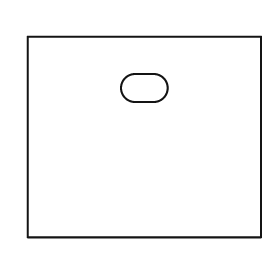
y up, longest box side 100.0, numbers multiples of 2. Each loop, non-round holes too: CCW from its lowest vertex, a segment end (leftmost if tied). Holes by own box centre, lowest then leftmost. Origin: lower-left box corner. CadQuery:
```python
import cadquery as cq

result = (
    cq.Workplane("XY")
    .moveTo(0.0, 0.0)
    .lineTo(100.0, 0.0)
    .lineTo(100.0, 86.0)
    .lineTo(0.0, 86.0)
    .close()
    .moveTo(46.0, 58.0)
    .lineTo(54.0, 58.0)
    .threePointArc((60.0, 64.0), (54.0, 70.0))
    .lineTo(46.0, 70.0)
    .threePointArc((40.0, 64.0), (46.0, 58.0))
    .close()
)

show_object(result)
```